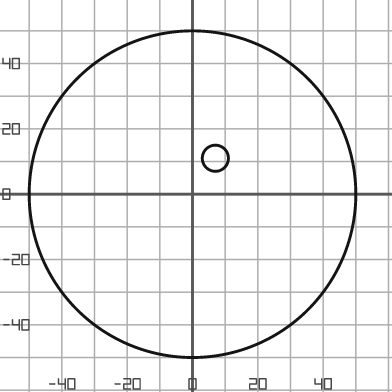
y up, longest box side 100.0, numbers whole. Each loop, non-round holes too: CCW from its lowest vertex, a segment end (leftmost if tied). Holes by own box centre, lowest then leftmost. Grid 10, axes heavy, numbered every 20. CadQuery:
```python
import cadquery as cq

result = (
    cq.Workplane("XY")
    .moveTo(0.0, 0.0)
    .circle(50.0)
    .moveTo(7.0, 11.0)
    .circle(4.0)
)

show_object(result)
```